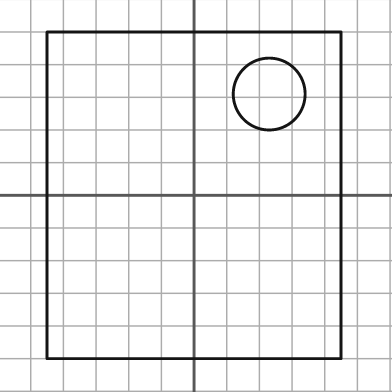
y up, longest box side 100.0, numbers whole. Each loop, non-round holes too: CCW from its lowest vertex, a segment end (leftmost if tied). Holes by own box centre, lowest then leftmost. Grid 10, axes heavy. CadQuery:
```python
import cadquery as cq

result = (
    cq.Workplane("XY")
    .moveTo(-45.0, -50.0)
    .lineTo(45.0, -50.0)
    .lineTo(45.0, 50.0)
    .lineTo(-45.0, 50.0)
    .close()
    .moveTo(23.0, 31.0)
    .circle(11.0)
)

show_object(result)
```